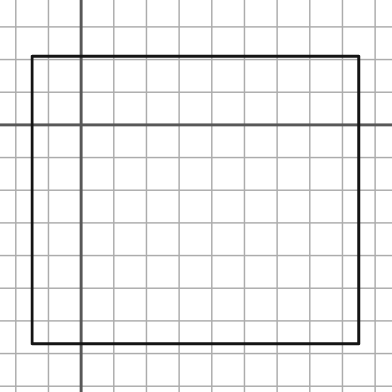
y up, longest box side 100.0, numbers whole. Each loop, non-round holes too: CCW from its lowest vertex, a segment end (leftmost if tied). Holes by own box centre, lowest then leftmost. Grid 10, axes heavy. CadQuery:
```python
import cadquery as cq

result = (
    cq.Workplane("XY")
    .moveTo(-15.0, -67.0)
    .lineTo(85.0, -67.0)
    .lineTo(85.0, 21.0)
    .lineTo(-15.0, 21.0)
    .close()
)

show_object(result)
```